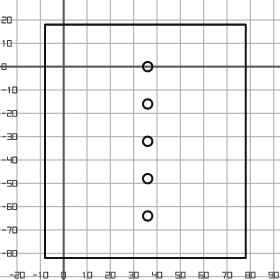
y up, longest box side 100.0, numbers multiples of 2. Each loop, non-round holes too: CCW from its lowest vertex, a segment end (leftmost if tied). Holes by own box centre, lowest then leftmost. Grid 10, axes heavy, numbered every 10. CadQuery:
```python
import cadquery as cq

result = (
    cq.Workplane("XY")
    .moveTo(-8.0, -82.0)
    .lineTo(78.0, -82.0)
    .lineTo(78.0, 18.0)
    .lineTo(-8.0, 18.0)
    .close()
    .moveTo(36.0, -64.0)
    .circle(2.0)
    .moveTo(36.0, -48.0)
    .circle(2.0)
    .moveTo(36.0, -32.0)
    .circle(2.0)
    .moveTo(36.0, -16.0)
    .circle(2.0)
    .moveTo(36.0, 0.0)
    .circle(2.0)
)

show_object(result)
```